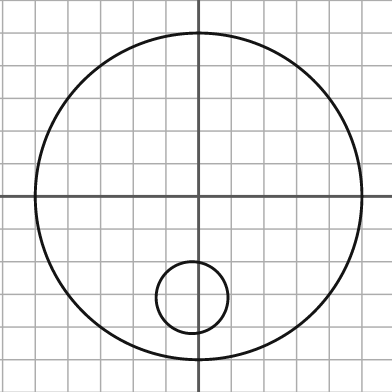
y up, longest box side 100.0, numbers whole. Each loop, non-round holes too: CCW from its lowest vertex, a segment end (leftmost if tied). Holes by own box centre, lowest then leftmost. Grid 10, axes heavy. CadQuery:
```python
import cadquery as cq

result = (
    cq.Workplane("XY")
    .moveTo(0.0, 0.0)
    .circle(50.0)
    .moveTo(-2.0, -31.0)
    .circle(11.0)
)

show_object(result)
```